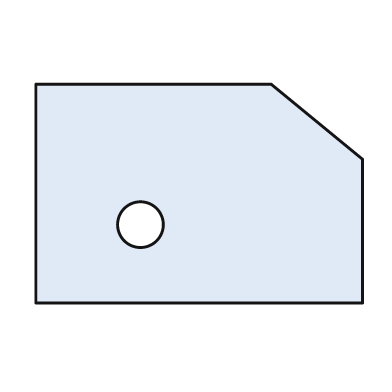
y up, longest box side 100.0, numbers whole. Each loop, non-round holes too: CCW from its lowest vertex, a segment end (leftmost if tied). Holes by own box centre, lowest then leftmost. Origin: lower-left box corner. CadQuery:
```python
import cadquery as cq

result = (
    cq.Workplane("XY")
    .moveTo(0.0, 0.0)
    .lineTo(100.0, 0.0)
    .lineTo(100.0, 44.0)
    .lineTo(72.0, 67.0)
    .lineTo(0.0, 67.0)
    .close()
    .moveTo(32.0, 24.0)
    .circle(7.0)
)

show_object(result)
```